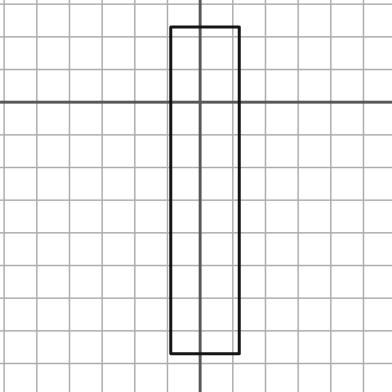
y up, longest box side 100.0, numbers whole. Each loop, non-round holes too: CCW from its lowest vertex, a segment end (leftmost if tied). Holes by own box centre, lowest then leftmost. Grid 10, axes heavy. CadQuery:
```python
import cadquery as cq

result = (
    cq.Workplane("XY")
    .moveTo(-9.0, -77.0)
    .lineTo(12.0, -77.0)
    .lineTo(12.0, 23.0)
    .lineTo(-9.0, 23.0)
    .close()
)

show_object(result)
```